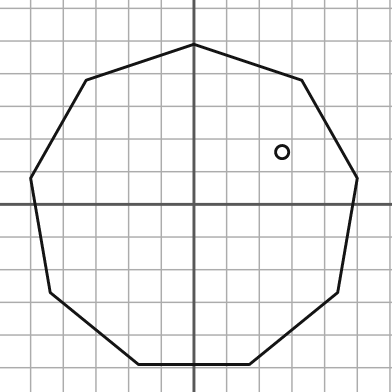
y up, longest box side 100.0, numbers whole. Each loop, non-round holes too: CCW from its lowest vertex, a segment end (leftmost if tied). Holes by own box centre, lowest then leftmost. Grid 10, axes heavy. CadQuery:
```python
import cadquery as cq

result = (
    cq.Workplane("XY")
    .moveTo(-17.0, -49.0)
    .lineTo(17.0, -49.0)
    .lineTo(44.0, -27.0)
    .lineTo(50.0, 8.0)
    .lineTo(33.0, 38.0)
    .lineTo(0.0, 49.0)
    .lineTo(-33.0, 38.0)
    .lineTo(-50.0, 8.0)
    .lineTo(-44.0, -27.0)
    .close()
    .moveTo(27.0, 16.0)
    .circle(2.0)
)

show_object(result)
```